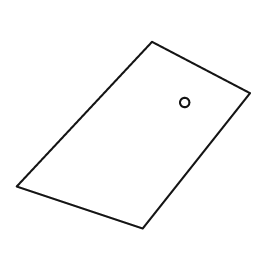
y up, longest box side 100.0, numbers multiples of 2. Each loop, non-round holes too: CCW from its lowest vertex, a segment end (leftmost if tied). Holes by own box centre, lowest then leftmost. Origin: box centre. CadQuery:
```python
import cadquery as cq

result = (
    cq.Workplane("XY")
    .moveTo(4.0, -40.0)
    .lineTo(50.0, 18.0)
    .lineTo(8.0, 40.0)
    .lineTo(-50.0, -22.0)
    .close()
    .moveTo(22.0, 14.0)
    .circle(2.0)
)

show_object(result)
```